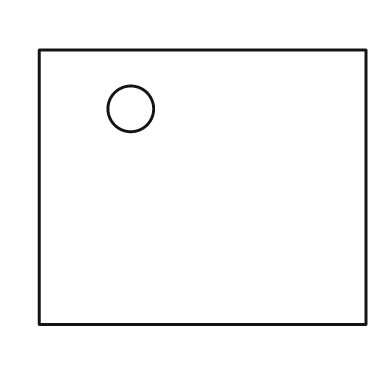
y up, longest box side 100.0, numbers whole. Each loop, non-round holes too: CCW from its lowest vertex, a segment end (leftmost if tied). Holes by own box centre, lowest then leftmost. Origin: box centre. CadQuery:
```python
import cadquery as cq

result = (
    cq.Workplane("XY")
    .moveTo(-50.0, -42.0)
    .lineTo(50.0, -42.0)
    .lineTo(50.0, 42.0)
    .lineTo(-50.0, 42.0)
    .close()
    .moveTo(-22.0, 24.0)
    .circle(7.0)
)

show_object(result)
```